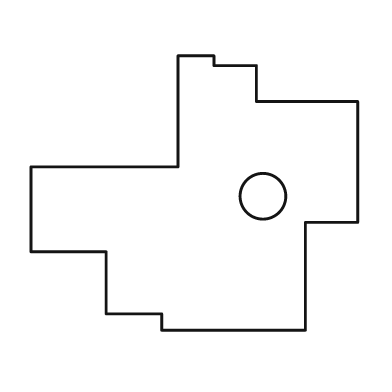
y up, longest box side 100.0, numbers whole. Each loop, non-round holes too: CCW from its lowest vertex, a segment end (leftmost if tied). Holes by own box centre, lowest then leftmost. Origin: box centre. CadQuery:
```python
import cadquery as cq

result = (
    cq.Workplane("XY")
    .moveTo(-10.0, -42.0)
    .lineTo(34.0, -42.0)
    .lineTo(34.0, -9.0)
    .lineTo(50.0, -9.0)
    .lineTo(50.0, 28.0)
    .lineTo(19.0, 28.0)
    .lineTo(19.0, 39.0)
    .lineTo(6.0, 39.0)
    .lineTo(6.0, 42.0)
    .lineTo(-5.0, 42.0)
    .lineTo(-5.0, 8.0)
    .lineTo(-50.0, 8.0)
    .lineTo(-50.0, -18.0)
    .lineTo(-27.0, -18.0)
    .lineTo(-27.0, -37.0)
    .lineTo(-10.0, -37.0)
    .close()
    .moveTo(21.0, -1.0)
    .circle(7.0)
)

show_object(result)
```